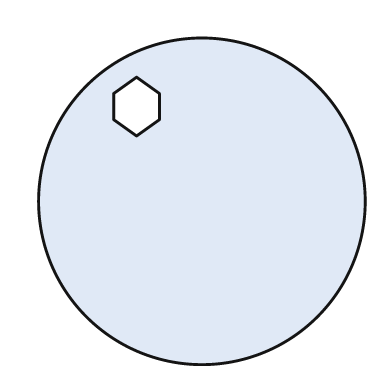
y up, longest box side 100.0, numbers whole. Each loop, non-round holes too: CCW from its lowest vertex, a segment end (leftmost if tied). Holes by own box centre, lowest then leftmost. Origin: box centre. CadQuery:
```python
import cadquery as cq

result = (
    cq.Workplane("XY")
    .moveTo(0.0, 0.0)
    .circle(50.0)
    .moveTo(-20.0, 20.0)
    .lineTo(-13.0, 25.0)
    .lineTo(-13.0, 33.0)
    .lineTo(-20.0, 38.0)
    .lineTo(-27.0, 33.0)
    .lineTo(-27.0, 25.0)
    .close()
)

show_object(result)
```